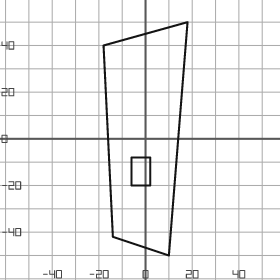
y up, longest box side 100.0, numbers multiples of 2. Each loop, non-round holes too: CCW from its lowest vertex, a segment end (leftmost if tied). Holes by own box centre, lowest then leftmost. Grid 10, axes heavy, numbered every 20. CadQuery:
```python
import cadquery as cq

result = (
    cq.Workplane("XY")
    .moveTo(10.0, -50.0)
    .lineTo(18.0, 50.0)
    .lineTo(-18.0, 40.0)
    .lineTo(-14.0, -42.0)
    .close()
    .moveTo(-6.0, -20.0)
    .lineTo(2.0, -20.0)
    .lineTo(2.0, -8.0)
    .lineTo(-6.0, -8.0)
    .close()
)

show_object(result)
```